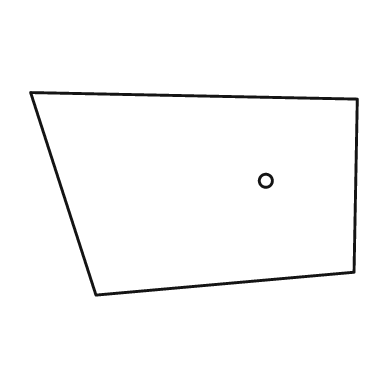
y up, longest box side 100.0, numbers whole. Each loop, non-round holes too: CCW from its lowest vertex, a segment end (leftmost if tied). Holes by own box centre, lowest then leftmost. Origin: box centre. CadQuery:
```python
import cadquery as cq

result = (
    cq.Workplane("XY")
    .moveTo(-30.0, -31.0)
    .lineTo(49.0, -24.0)
    .lineTo(50.0, 29.0)
    .lineTo(-50.0, 31.0)
    .close()
    .moveTo(22.0, 4.0)
    .circle(2.0)
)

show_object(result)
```